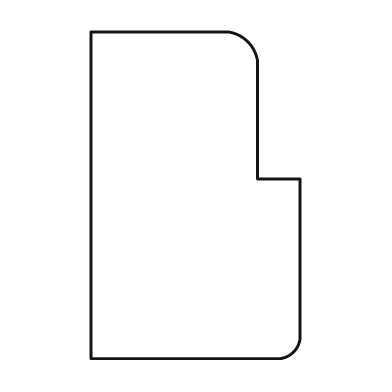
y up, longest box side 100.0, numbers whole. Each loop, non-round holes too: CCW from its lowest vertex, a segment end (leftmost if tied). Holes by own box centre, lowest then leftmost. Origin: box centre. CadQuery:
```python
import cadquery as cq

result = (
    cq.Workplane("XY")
    .moveTo(-32.0, -50.0)
    .lineTo(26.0, -50.0)
    .threePointArc((30.0, -48.0), (32.0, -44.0))
    .lineTo(32.0, 5.0)
    .lineTo(19.0, 5.0)
    .lineTo(19.0, 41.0)
    .threePointArc((16.0, 47.0), (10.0, 50.0))
    .lineTo(-32.0, 50.0)
    .close()
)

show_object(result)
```